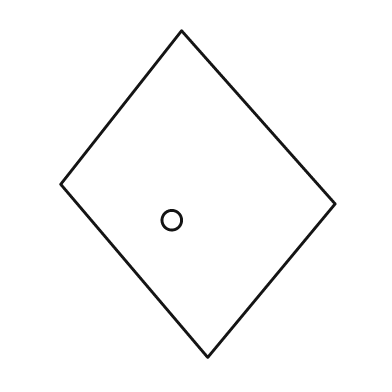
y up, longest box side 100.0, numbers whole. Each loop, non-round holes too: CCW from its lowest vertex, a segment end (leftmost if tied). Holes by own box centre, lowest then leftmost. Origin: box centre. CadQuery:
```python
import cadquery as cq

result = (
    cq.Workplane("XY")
    .moveTo(3.0, -50.0)
    .lineTo(42.0, -3.0)
    .lineTo(-5.0, 50.0)
    .lineTo(-42.0, 3.0)
    .close()
    .moveTo(-8.0, -8.0)
    .circle(3.0)
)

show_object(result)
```